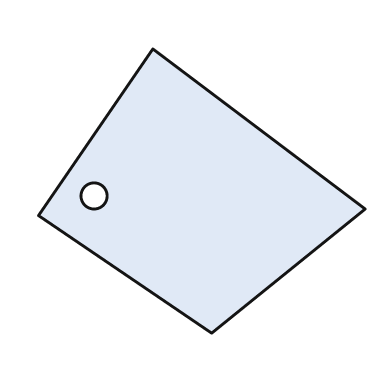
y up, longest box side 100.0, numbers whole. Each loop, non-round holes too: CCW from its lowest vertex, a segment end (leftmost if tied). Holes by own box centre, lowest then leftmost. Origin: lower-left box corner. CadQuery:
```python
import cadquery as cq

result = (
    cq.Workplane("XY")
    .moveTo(53.0, 0.0)
    .lineTo(100.0, 38.0)
    .lineTo(35.0, 87.0)
    .lineTo(0.0, 36.0)
    .close()
    .moveTo(17.0, 42.0)
    .circle(4.0)
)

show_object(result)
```